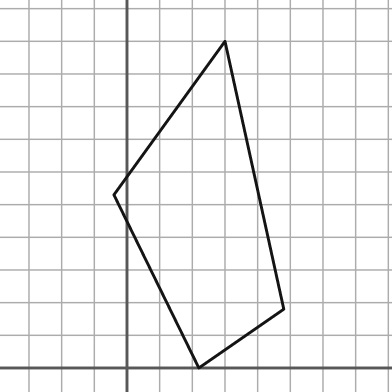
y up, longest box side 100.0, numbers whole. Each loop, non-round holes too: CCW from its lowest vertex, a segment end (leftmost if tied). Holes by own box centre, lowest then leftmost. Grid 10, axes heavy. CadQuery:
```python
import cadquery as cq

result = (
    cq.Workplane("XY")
    .moveTo(22.0, 0.0)
    .lineTo(48.0, 18.0)
    .lineTo(30.0, 100.0)
    .lineTo(-4.0, 53.0)
    .close()
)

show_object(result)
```